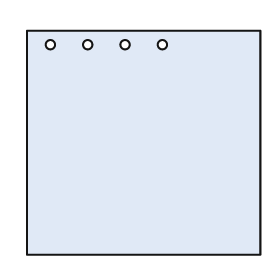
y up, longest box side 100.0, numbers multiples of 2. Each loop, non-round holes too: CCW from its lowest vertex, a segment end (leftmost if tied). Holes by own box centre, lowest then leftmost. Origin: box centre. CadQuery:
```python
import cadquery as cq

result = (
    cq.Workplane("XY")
    .moveTo(-50.0, -48.0)
    .lineTo(50.0, -48.0)
    .lineTo(50.0, 48.0)
    .lineTo(-50.0, 48.0)
    .close()
    .moveTo(-40.0, 42.0)
    .circle(2.0)
    .moveTo(-24.0, 42.0)
    .circle(2.0)
    .moveTo(-8.0, 42.0)
    .circle(2.0)
    .moveTo(8.0, 42.0)
    .circle(2.0)
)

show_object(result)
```